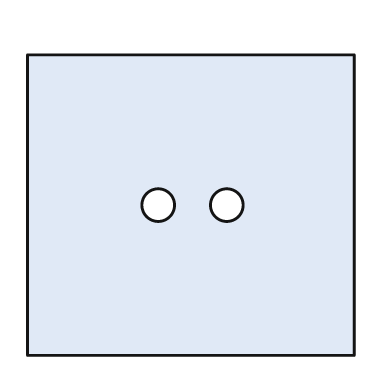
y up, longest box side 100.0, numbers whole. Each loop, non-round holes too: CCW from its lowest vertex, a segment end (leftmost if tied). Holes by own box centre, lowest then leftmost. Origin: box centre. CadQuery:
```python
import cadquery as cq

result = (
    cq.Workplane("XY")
    .moveTo(-50.0, -46.0)
    .lineTo(50.0, -46.0)
    .lineTo(50.0, 46.0)
    .lineTo(-50.0, 46.0)
    .close()
    .moveTo(-10.0, 0.0)
    .circle(5.0)
    .moveTo(11.0, 0.0)
    .circle(5.0)
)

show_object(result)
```